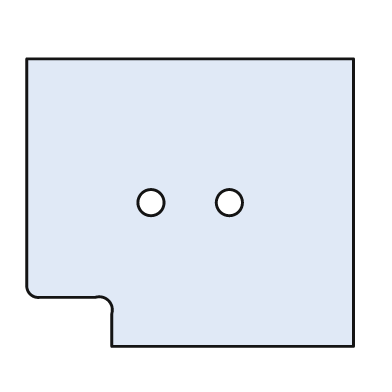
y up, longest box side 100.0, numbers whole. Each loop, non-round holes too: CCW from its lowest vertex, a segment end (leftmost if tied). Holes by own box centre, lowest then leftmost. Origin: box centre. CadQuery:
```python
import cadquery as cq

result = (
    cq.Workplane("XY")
    .moveTo(-24.0, -44.0)
    .lineTo(50.0, -44.0)
    .lineTo(50.0, 44.0)
    .lineTo(-50.0, 44.0)
    .lineTo(-50.0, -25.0)
    .threePointArc((-49.0, -28.0), (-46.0, -29.0))
    .lineTo(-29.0, -29.0)
    .threePointArc((-25.0, -30.0), (-24.0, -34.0))
    .close()
    .moveTo(-12.0, 0.0)
    .circle(4.0)
    .moveTo(12.0, 0.0)
    .circle(4.0)
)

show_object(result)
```